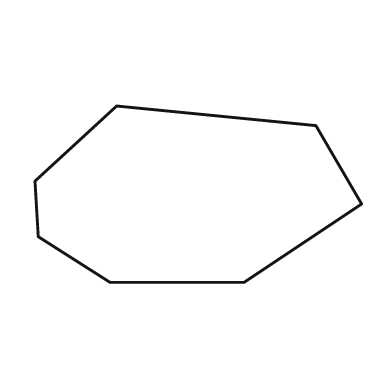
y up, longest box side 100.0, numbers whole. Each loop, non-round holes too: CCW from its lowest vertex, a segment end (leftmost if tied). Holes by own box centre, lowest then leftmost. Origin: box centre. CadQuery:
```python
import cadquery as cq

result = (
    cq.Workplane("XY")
    .moveTo(-27.0, -27.0)
    .lineTo(14.0, -27.0)
    .lineTo(50.0, -3.0)
    .lineTo(36.0, 21.0)
    .lineTo(-25.0, 27.0)
    .lineTo(-50.0, 4.0)
    .lineTo(-49.0, -13.0)
    .close()
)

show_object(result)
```